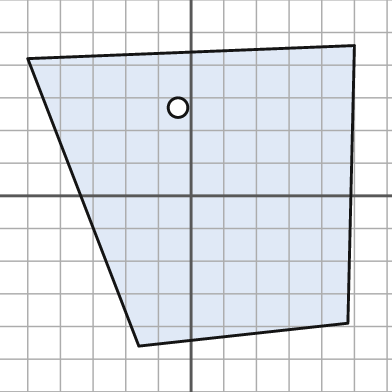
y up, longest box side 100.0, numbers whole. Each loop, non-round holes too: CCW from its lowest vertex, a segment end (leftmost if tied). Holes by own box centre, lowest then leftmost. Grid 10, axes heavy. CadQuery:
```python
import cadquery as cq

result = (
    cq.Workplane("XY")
    .moveTo(-16.0, -46.0)
    .lineTo(48.0, -39.0)
    .lineTo(50.0, 46.0)
    .lineTo(-50.0, 42.0)
    .close()
    .moveTo(-4.0, 27.0)
    .circle(3.0)
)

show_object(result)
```